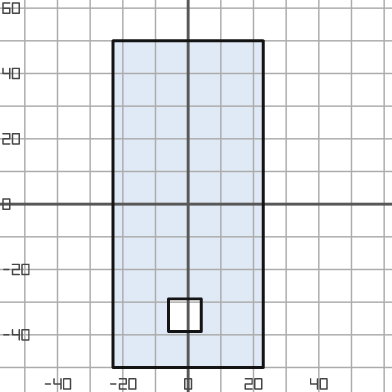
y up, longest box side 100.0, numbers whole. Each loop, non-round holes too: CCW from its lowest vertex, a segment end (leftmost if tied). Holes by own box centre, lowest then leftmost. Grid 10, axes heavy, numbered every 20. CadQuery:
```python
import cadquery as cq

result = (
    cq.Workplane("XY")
    .moveTo(-23.0, -50.0)
    .lineTo(23.0, -50.0)
    .lineTo(23.0, 50.0)
    .lineTo(-23.0, 50.0)
    .close()
    .moveTo(-6.0, -39.0)
    .lineTo(4.0, -39.0)
    .lineTo(4.0, -29.0)
    .lineTo(-6.0, -29.0)
    .close()
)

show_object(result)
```